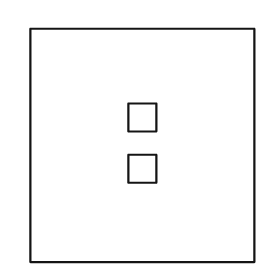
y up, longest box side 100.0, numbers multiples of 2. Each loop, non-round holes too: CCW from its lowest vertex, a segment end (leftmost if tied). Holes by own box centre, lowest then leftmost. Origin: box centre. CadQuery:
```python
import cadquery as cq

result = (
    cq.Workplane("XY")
    .moveTo(-48.0, -50.0)
    .lineTo(48.0, -50.0)
    .lineTo(48.0, 50.0)
    .lineTo(-48.0, 50.0)
    .close()
    .moveTo(-6.0, -16.0)
    .lineTo(6.0, -16.0)
    .lineTo(6.0, -4.0)
    .lineTo(-6.0, -4.0)
    .close()
    .moveTo(-6.0, 6.0)
    .lineTo(6.0, 6.0)
    .lineTo(6.0, 18.0)
    .lineTo(-6.0, 18.0)
    .close()
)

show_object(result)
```